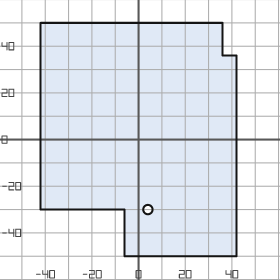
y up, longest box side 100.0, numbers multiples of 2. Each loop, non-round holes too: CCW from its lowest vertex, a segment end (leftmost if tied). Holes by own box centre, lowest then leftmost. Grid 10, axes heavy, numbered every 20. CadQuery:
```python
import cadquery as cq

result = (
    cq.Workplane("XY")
    .moveTo(-6.0, -50.0)
    .lineTo(42.0, -50.0)
    .lineTo(42.0, 36.0)
    .lineTo(36.0, 36.0)
    .lineTo(36.0, 50.0)
    .lineTo(-42.0, 50.0)
    .lineTo(-42.0, -30.0)
    .lineTo(-6.0, -30.0)
    .close()
    .moveTo(4.0, -30.0)
    .circle(2.0)
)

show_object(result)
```